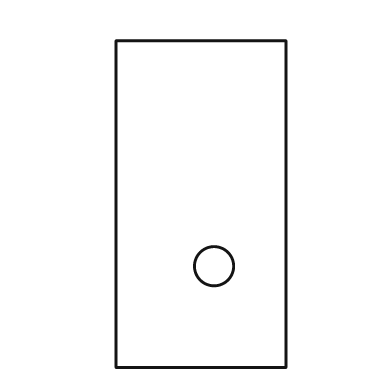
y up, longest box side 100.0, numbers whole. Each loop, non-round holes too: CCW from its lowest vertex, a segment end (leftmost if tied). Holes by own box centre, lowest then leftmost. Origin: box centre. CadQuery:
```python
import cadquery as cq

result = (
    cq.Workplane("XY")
    .moveTo(-26.0, -50.0)
    .lineTo(26.0, -50.0)
    .lineTo(26.0, 50.0)
    .lineTo(-26.0, 50.0)
    .close()
    .moveTo(4.0, -19.0)
    .circle(6.0)
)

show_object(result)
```